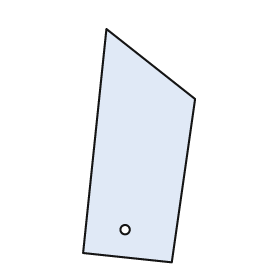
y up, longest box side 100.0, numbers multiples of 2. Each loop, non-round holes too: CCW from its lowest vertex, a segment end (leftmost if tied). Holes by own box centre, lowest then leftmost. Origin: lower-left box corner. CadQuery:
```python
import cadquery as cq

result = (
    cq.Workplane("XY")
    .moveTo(38.0, 0.0)
    .lineTo(48.0, 70.0)
    .lineTo(10.0, 100.0)
    .lineTo(0.0, 4.0)
    .close()
    .moveTo(18.0, 14.0)
    .circle(2.0)
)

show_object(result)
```